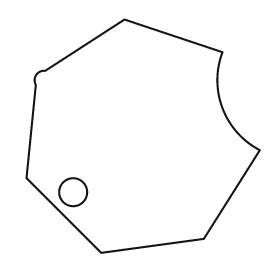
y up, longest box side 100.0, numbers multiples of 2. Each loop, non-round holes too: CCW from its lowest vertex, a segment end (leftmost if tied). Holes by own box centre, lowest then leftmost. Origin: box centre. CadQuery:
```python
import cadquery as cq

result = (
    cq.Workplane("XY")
    .moveTo(-18.0, -50.0)
    .lineTo(26.0, -44.0)
    .lineTo(50.0, -6.0)
    .threePointArc((34.0, 12.0), (34.0, 36.0))
    .lineTo(-8.0, 50.0)
    .lineTo(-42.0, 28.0)
    .threePointArc((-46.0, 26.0), (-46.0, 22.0))
    .lineTo(-50.0, -18.0)
    .close()
    .moveTo(-30.0, -24.0)
    .circle(6.0)
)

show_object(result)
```